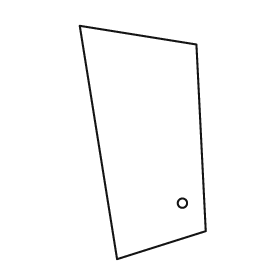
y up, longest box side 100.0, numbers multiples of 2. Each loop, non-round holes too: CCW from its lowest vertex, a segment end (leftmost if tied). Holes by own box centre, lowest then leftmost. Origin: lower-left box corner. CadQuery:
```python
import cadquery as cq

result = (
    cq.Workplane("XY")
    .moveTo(16.0, 0.0)
    .lineTo(54.0, 12.0)
    .lineTo(50.0, 92.0)
    .lineTo(0.0, 100.0)
    .close()
    .moveTo(44.0, 24.0)
    .circle(2.0)
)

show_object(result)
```